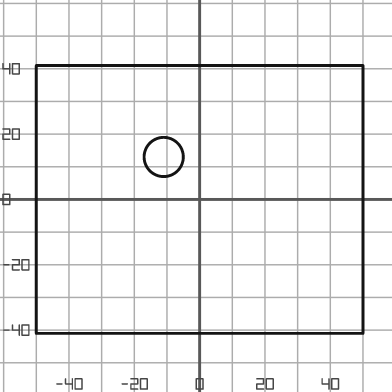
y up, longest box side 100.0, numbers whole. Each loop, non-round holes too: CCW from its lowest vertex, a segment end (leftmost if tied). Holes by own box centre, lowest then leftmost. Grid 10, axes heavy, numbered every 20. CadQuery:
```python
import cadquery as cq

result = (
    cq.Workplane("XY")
    .moveTo(-50.0, -41.0)
    .lineTo(50.0, -41.0)
    .lineTo(50.0, 41.0)
    .lineTo(-50.0, 41.0)
    .close()
    .moveTo(-11.0, 13.0)
    .circle(6.0)
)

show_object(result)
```